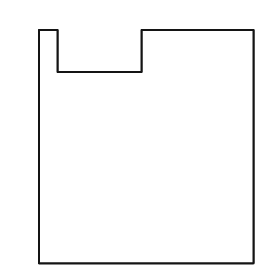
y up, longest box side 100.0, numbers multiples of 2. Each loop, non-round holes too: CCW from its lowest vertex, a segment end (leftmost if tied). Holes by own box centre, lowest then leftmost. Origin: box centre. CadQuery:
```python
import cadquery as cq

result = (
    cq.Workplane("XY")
    .moveTo(-46.0, -50.0)
    .lineTo(46.0, -50.0)
    .lineTo(46.0, 50.0)
    .lineTo(-2.0, 50.0)
    .lineTo(-2.0, 32.0)
    .lineTo(-38.0, 32.0)
    .lineTo(-38.0, 50.0)
    .lineTo(-46.0, 50.0)
    .close()
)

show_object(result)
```